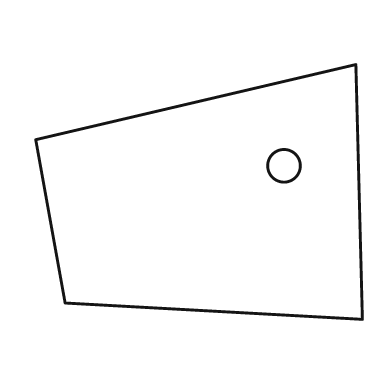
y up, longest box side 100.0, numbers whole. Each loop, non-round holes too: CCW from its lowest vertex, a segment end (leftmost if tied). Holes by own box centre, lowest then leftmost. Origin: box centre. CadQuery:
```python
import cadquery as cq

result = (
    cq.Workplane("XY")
    .moveTo(50.0, -39.0)
    .lineTo(48.0, 39.0)
    .lineTo(-50.0, 16.0)
    .lineTo(-41.0, -34.0)
    .close()
    .moveTo(26.0, 8.0)
    .circle(5.0)
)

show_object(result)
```